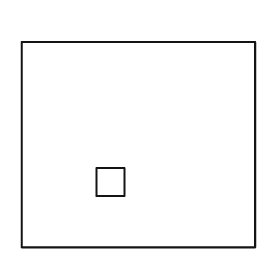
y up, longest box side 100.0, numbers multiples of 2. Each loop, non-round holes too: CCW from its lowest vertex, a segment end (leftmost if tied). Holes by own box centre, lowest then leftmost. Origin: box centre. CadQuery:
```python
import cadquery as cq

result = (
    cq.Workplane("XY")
    .moveTo(-50.0, -44.0)
    .lineTo(50.0, -44.0)
    .lineTo(50.0, 44.0)
    .lineTo(-50.0, 44.0)
    .close()
    .moveTo(-18.0, -22.0)
    .lineTo(-6.0, -22.0)
    .lineTo(-6.0, -10.0)
    .lineTo(-18.0, -10.0)
    .close()
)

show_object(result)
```